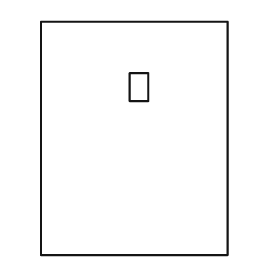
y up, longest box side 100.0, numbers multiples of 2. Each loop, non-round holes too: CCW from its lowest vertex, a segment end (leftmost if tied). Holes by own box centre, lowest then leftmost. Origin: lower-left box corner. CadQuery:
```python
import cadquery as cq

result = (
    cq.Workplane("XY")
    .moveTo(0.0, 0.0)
    .lineTo(80.0, 0.0)
    .lineTo(80.0, 100.0)
    .lineTo(0.0, 100.0)
    .close()
    .moveTo(38.0, 66.0)
    .lineTo(46.0, 66.0)
    .lineTo(46.0, 78.0)
    .lineTo(38.0, 78.0)
    .close()
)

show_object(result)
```